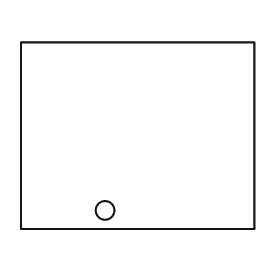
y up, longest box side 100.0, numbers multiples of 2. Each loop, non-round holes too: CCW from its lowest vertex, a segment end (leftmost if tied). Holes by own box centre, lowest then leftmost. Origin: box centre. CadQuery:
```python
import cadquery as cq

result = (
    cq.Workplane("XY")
    .moveTo(-50.0, -40.0)
    .lineTo(50.0, -40.0)
    .lineTo(50.0, 40.0)
    .lineTo(-50.0, 40.0)
    .close()
    .moveTo(-14.0, -32.0)
    .circle(4.0)
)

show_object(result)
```